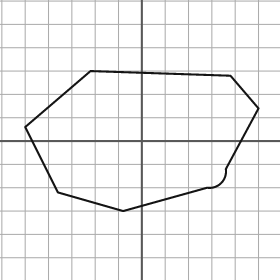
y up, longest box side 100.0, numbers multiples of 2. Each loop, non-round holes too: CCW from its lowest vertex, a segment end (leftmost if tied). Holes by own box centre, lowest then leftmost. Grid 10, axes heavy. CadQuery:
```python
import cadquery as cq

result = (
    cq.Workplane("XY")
    .moveTo(-8.0, -30.0)
    .lineTo(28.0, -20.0)
    .threePointArc((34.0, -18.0), (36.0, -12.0))
    .lineTo(50.0, 14.0)
    .lineTo(38.0, 28.0)
    .lineTo(-22.0, 30.0)
    .lineTo(-50.0, 6.0)
    .lineTo(-36.0, -22.0)
    .close()
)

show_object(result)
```